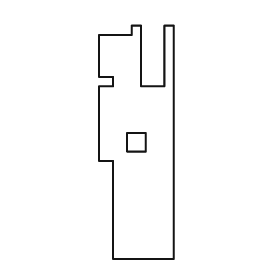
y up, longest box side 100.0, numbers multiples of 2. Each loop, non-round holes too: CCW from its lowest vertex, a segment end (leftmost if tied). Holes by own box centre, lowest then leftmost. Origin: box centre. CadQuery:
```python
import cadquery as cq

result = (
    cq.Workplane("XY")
    .moveTo(-10.0, -50.0)
    .lineTo(16.0, -50.0)
    .lineTo(16.0, 50.0)
    .lineTo(12.0, 50.0)
    .lineTo(12.0, 24.0)
    .lineTo(2.0, 24.0)
    .lineTo(2.0, 50.0)
    .lineTo(-2.0, 50.0)
    .lineTo(-2.0, 46.0)
    .lineTo(-16.0, 46.0)
    .lineTo(-16.0, 28.0)
    .lineTo(-10.0, 28.0)
    .lineTo(-10.0, 24.0)
    .lineTo(-16.0, 24.0)
    .lineTo(-16.0, -8.0)
    .lineTo(-10.0, -8.0)
    .close()
    .moveTo(-4.0, -4.0)
    .lineTo(4.0, -4.0)
    .lineTo(4.0, 4.0)
    .lineTo(-4.0, 4.0)
    .close()
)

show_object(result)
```